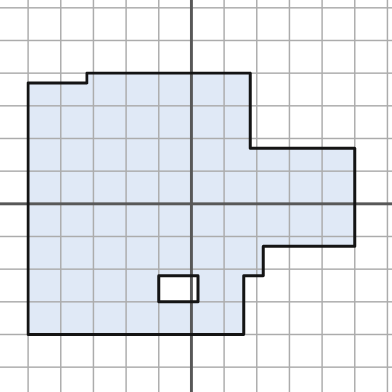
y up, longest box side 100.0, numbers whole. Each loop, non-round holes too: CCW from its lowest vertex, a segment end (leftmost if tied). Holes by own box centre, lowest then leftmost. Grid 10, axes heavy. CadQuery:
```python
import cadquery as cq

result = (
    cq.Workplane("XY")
    .moveTo(-50.0, -40.0)
    .lineTo(16.0, -40.0)
    .lineTo(16.0, -22.0)
    .lineTo(22.0, -22.0)
    .lineTo(22.0, -13.0)
    .lineTo(50.0, -13.0)
    .lineTo(50.0, 17.0)
    .lineTo(18.0, 17.0)
    .lineTo(18.0, 40.0)
    .lineTo(-32.0, 40.0)
    .lineTo(-32.0, 37.0)
    .lineTo(-50.0, 37.0)
    .close()
    .moveTo(-10.0, -30.0)
    .lineTo(2.0, -30.0)
    .lineTo(2.0, -22.0)
    .lineTo(-10.0, -22.0)
    .close()
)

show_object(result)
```